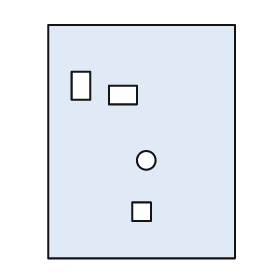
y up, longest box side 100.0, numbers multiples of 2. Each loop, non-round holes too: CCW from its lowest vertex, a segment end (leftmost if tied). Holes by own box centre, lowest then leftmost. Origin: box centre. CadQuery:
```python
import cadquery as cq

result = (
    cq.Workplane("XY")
    .moveTo(-40.0, -50.0)
    .lineTo(40.0, -50.0)
    .lineTo(40.0, 50.0)
    .lineTo(-40.0, 50.0)
    .close()
    .moveTo(-4.0, -34.0)
    .lineTo(4.0, -34.0)
    .lineTo(4.0, -26.0)
    .lineTo(-4.0, -26.0)
    .close()
    .moveTo(2.0, -8.0)
    .circle(4.0)
    .moveTo(-14.0, 16.0)
    .lineTo(-2.0, 16.0)
    .lineTo(-2.0, 24.0)
    .lineTo(-14.0, 24.0)
    .close()
    .moveTo(-30.0, 18.0)
    .lineTo(-22.0, 18.0)
    .lineTo(-22.0, 30.0)
    .lineTo(-30.0, 30.0)
    .close()
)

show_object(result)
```